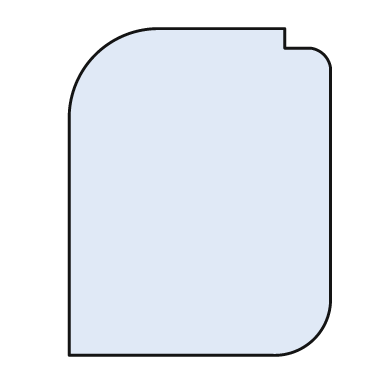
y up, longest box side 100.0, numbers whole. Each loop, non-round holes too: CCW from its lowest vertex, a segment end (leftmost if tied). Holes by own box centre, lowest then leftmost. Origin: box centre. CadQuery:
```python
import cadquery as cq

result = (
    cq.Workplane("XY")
    .moveTo(-40.0, -50.0)
    .lineTo(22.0, -50.0)
    .threePointArc((35.0, -45.0), (40.0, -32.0))
    .lineTo(40.0, 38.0)
    .threePointArc((38.0, 42.0), (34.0, 44.0))
    .lineTo(26.0, 44.0)
    .lineTo(26.0, 50.0)
    .lineTo(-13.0, 50.0)
    .threePointArc((-32.0, 42.0), (-40.0, 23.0))
    .close()
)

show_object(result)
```